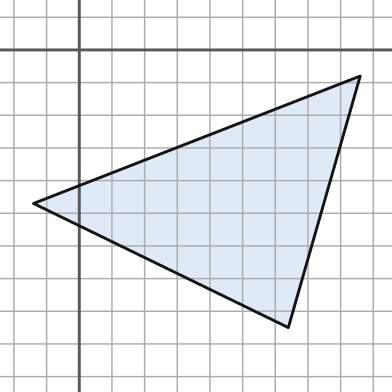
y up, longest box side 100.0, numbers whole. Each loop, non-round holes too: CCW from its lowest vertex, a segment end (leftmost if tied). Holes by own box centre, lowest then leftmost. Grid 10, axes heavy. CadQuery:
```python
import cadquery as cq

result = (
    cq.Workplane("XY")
    .moveTo(64.0, -85.0)
    .lineTo(86.0, -8.0)
    .lineTo(-14.0, -47.0)
    .close()
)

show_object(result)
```